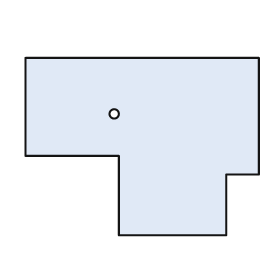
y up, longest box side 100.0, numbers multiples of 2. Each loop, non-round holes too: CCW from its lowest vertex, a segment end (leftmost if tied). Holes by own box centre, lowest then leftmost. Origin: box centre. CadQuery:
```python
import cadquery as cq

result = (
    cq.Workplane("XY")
    .moveTo(-10.0, -38.0)
    .lineTo(36.0, -38.0)
    .lineTo(36.0, -12.0)
    .lineTo(50.0, -12.0)
    .lineTo(50.0, 38.0)
    .lineTo(-50.0, 38.0)
    .lineTo(-50.0, -4.0)
    .lineTo(-10.0, -4.0)
    .close()
    .moveTo(-12.0, 14.0)
    .circle(2.0)
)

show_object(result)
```